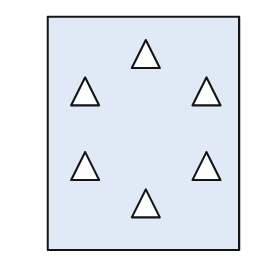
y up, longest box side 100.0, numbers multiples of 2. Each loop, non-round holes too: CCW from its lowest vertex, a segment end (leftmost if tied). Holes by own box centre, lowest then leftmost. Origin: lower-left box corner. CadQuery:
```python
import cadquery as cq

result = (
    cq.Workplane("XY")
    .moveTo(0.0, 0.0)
    .lineTo(82.0, 0.0)
    .lineTo(82.0, 100.0)
    .lineTo(0.0, 100.0)
    .close()
    .moveTo(36.0, 14.0)
    .lineTo(48.0, 14.0)
    .lineTo(42.0, 26.0)
    .close()
    .moveTo(10.0, 30.0)
    .lineTo(22.0, 30.0)
    .lineTo(16.0, 42.0)
    .close()
    .moveTo(62.0, 30.0)
    .lineTo(74.0, 30.0)
    .lineTo(68.0, 42.0)
    .close()
    .moveTo(10.0, 62.0)
    .lineTo(22.0, 62.0)
    .lineTo(16.0, 74.0)
    .close()
    .moveTo(62.0, 62.0)
    .lineTo(74.0, 62.0)
    .lineTo(68.0, 74.0)
    .close()
    .moveTo(36.0, 78.0)
    .lineTo(48.0, 78.0)
    .lineTo(42.0, 90.0)
    .close()
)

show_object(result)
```